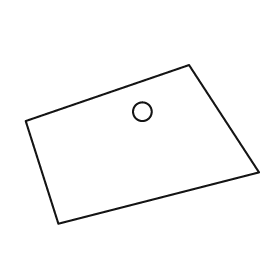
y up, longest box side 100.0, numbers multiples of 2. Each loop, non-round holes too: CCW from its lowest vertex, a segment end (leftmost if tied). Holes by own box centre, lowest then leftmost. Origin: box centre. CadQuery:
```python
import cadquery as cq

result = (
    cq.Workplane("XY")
    .moveTo(-36.0, -34.0)
    .lineTo(50.0, -12.0)
    .lineTo(20.0, 34.0)
    .lineTo(-50.0, 10.0)
    .close()
    .moveTo(0.0, 14.0)
    .circle(4.0)
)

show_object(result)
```